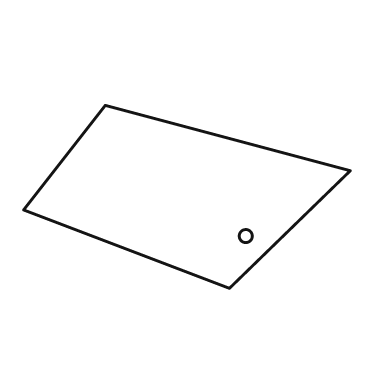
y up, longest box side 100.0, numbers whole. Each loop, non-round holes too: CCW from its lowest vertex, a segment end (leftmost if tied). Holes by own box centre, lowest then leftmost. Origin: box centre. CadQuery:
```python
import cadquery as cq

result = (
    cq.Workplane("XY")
    .moveTo(13.0, -28.0)
    .lineTo(50.0, 8.0)
    .lineTo(-25.0, 28.0)
    .lineTo(-50.0, -4.0)
    .close()
    .moveTo(18.0, -12.0)
    .circle(2.0)
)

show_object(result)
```